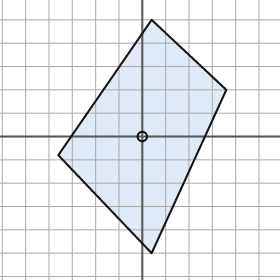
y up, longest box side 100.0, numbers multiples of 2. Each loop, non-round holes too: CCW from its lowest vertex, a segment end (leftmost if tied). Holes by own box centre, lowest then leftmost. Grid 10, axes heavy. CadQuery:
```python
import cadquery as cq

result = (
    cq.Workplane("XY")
    .moveTo(4.0, -50.0)
    .lineTo(36.0, 20.0)
    .lineTo(4.0, 50.0)
    .lineTo(-36.0, -8.0)
    .close()
    .moveTo(0.0, 0.0)
    .circle(2.0)
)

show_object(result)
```